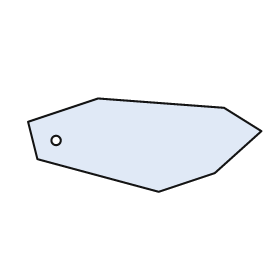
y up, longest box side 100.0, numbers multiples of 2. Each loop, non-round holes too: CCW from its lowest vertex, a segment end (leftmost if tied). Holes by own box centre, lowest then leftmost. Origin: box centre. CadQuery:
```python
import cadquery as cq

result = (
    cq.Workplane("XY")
    .moveTo(6.0, -20.0)
    .lineTo(30.0, -12.0)
    .lineTo(50.0, 6.0)
    .lineTo(34.0, 16.0)
    .lineTo(-20.0, 20.0)
    .lineTo(-50.0, 10.0)
    .lineTo(-46.0, -6.0)
    .close()
    .moveTo(-38.0, 2.0)
    .circle(2.0)
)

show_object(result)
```